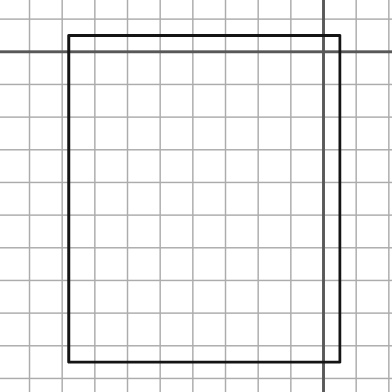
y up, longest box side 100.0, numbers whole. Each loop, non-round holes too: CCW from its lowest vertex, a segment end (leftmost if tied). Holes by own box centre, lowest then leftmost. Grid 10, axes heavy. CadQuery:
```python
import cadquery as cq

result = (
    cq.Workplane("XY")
    .moveTo(-78.0, -95.0)
    .lineTo(5.0, -95.0)
    .lineTo(5.0, 5.0)
    .lineTo(-78.0, 5.0)
    .close()
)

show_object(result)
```